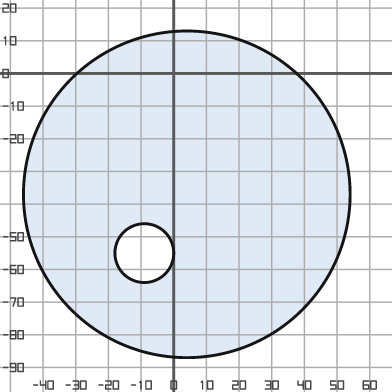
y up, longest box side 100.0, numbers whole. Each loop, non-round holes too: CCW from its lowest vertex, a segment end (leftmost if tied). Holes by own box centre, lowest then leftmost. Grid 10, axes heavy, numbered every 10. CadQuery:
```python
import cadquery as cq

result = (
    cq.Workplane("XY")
    .moveTo(4.0, -37.0)
    .circle(50.0)
    .moveTo(-9.0, -55.0)
    .circle(9.0)
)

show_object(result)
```